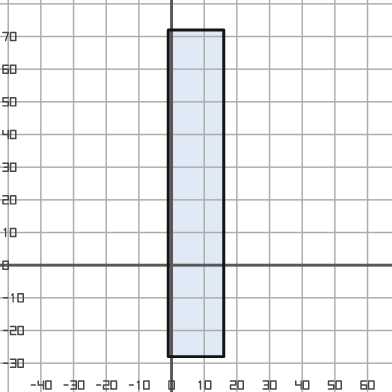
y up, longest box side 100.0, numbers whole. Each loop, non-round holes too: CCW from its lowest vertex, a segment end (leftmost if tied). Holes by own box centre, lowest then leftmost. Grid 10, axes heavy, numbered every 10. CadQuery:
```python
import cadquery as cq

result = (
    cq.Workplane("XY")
    .moveTo(-1.0, -28.0)
    .lineTo(16.0, -28.0)
    .lineTo(16.0, 72.0)
    .lineTo(-1.0, 72.0)
    .close()
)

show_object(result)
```